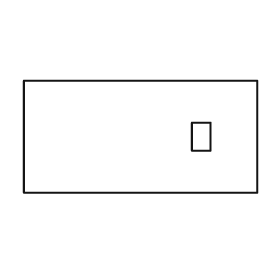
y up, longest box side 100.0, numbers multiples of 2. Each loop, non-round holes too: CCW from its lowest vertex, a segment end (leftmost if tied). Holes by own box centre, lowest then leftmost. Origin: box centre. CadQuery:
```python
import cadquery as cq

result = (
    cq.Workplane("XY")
    .moveTo(-50.0, -24.0)
    .lineTo(50.0, -24.0)
    .lineTo(50.0, 24.0)
    .lineTo(-50.0, 24.0)
    .close()
    .moveTo(22.0, -6.0)
    .lineTo(30.0, -6.0)
    .lineTo(30.0, 6.0)
    .lineTo(22.0, 6.0)
    .close()
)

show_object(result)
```